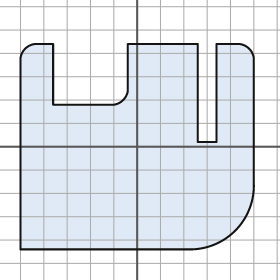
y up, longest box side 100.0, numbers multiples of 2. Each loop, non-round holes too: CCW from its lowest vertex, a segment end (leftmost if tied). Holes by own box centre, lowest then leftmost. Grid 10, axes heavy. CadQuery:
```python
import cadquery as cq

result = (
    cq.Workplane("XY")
    .moveTo(-50.0, -44.0)
    .lineTo(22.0, -44.0)
    .threePointArc((42.0, -36.0), (50.0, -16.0))
    .lineTo(50.0, 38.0)
    .threePointArc((48.0, 42.0), (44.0, 44.0))
    .lineTo(34.0, 44.0)
    .lineTo(34.0, 2.0)
    .lineTo(26.0, 2.0)
    .lineTo(26.0, 44.0)
    .lineTo(-4.0, 44.0)
    .lineTo(-4.0, 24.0)
    .threePointArc((-6.0, 20.0), (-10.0, 18.0))
    .lineTo(-36.0, 18.0)
    .lineTo(-36.0, 44.0)
    .lineTo(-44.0, 44.0)
    .threePointArc((-48.0, 42.0), (-50.0, 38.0))
    .close()
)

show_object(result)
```